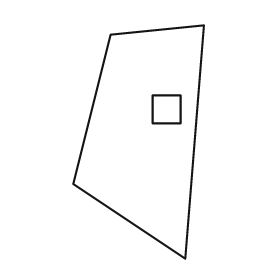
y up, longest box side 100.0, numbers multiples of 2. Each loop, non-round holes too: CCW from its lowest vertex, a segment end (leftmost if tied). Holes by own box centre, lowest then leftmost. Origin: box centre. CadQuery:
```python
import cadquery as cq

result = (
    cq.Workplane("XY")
    .moveTo(20.0, -50.0)
    .lineTo(28.0, 50.0)
    .lineTo(-12.0, 46.0)
    .lineTo(-28.0, -18.0)
    .close()
    .moveTo(6.0, 8.0)
    .lineTo(18.0, 8.0)
    .lineTo(18.0, 20.0)
    .lineTo(6.0, 20.0)
    .close()
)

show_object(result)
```